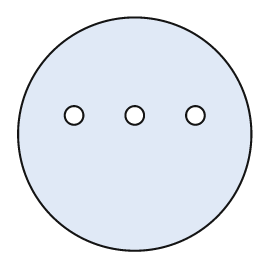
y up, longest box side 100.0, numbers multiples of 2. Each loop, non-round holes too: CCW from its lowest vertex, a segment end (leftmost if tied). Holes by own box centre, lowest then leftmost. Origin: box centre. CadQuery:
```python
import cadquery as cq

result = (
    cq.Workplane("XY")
    .moveTo(0.0, 0.0)
    .circle(50.0)
    .moveTo(-26.0, 8.0)
    .circle(4.0)
    .moveTo(0.0, 8.0)
    .circle(4.0)
    .moveTo(26.0, 8.0)
    .circle(4.0)
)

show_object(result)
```